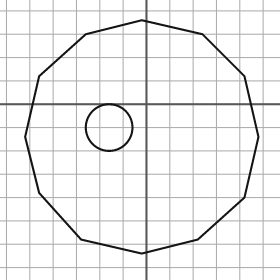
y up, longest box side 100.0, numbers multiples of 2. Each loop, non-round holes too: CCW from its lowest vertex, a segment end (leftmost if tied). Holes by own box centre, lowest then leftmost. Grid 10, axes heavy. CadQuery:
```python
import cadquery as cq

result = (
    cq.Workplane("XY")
    .moveTo(-2.0, -64.0)
    .lineTo(22.0, -58.0)
    .lineTo(42.0, -40.0)
    .lineTo(48.0, -14.0)
    .lineTo(42.0, 12.0)
    .lineTo(24.0, 30.0)
    .lineTo(-2.0, 36.0)
    .lineTo(-26.0, 30.0)
    .lineTo(-46.0, 12.0)
    .lineTo(-52.0, -14.0)
    .lineTo(-46.0, -38.0)
    .lineTo(-28.0, -58.0)
    .close()
    .moveTo(-16.0, -10.0)
    .circle(10.0)
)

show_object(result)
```